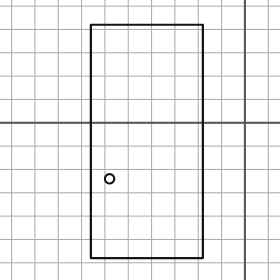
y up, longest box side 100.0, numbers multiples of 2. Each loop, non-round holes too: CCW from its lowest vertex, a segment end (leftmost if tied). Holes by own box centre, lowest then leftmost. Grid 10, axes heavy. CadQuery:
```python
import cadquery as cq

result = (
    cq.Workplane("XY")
    .moveTo(-66.0, -58.0)
    .lineTo(-18.0, -58.0)
    .lineTo(-18.0, 42.0)
    .lineTo(-66.0, 42.0)
    .close()
    .moveTo(-58.0, -24.0)
    .circle(2.0)
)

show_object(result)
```